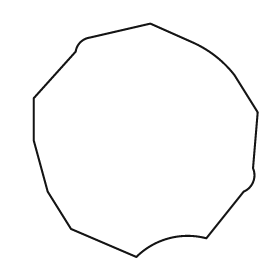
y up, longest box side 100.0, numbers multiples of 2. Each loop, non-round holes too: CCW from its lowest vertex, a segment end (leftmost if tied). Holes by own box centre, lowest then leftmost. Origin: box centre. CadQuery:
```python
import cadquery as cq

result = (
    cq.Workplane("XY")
    .moveTo(-4.0, -50.0)
    .threePointArc((10.0, -42.0), (26.0, -42.0))
    .lineTo(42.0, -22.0)
    .threePointArc((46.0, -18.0), (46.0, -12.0))
    .lineTo(48.0, 12.0)
    .lineTo(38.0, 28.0)
    .threePointArc((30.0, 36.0), (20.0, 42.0))
    .lineTo(2.0, 50.0)
    .lineTo(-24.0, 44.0)
    .threePointArc((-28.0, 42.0), (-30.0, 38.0))
    .lineTo(-48.0, 18.0)
    .lineTo(-48.0, 0.0)
    .lineTo(-42.0, -22.0)
    .lineTo(-32.0, -38.0)
    .close()
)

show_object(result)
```